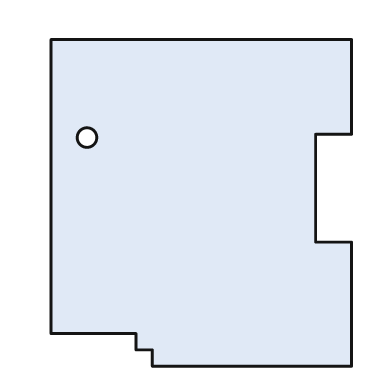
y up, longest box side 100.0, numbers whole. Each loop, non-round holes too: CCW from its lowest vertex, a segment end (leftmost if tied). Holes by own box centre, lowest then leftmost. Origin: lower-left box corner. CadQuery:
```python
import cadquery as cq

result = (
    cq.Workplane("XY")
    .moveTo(31.0, 0.0)
    .lineTo(92.0, 0.0)
    .lineTo(92.0, 38.0)
    .lineTo(81.0, 38.0)
    .lineTo(81.0, 71.0)
    .lineTo(92.0, 71.0)
    .lineTo(92.0, 100.0)
    .lineTo(0.0, 100.0)
    .lineTo(0.0, 10.0)
    .lineTo(26.0, 10.0)
    .lineTo(26.0, 5.0)
    .lineTo(31.0, 5.0)
    .close()
    .moveTo(11.0, 70.0)
    .circle(3.0)
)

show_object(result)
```